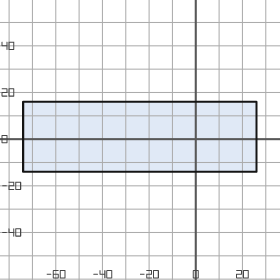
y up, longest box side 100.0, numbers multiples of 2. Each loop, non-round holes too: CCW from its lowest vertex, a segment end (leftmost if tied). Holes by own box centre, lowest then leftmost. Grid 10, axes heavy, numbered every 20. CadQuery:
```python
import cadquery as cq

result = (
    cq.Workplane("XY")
    .moveTo(-74.0, -14.0)
    .lineTo(26.0, -14.0)
    .lineTo(26.0, 16.0)
    .lineTo(-74.0, 16.0)
    .close()
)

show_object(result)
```